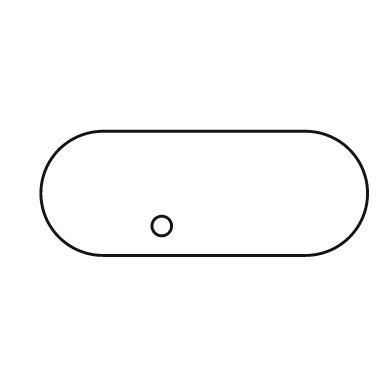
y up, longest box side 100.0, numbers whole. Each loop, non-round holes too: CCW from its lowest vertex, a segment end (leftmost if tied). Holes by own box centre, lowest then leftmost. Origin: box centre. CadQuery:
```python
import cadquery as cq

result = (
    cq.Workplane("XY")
    .moveTo(-31.0, -19.0)
    .lineTo(31.0, -19.0)
    .threePointArc((50.0, 0.0), (31.0, 19.0))
    .lineTo(-31.0, 19.0)
    .threePointArc((-50.0, 0.0), (-31.0, -19.0))
    .close()
    .moveTo(-13.0, -10.0)
    .circle(3.0)
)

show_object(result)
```